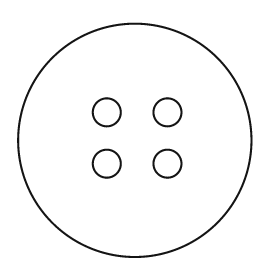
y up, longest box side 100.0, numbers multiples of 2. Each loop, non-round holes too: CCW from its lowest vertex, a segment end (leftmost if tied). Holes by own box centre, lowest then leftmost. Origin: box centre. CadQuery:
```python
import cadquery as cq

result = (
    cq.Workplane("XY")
    .moveTo(0.0, 0.0)
    .circle(50.0)
    .moveTo(-12.0, -10.0)
    .circle(6.0)
    .moveTo(14.0, -10.0)
    .circle(6.0)
    .moveTo(-12.0, 12.0)
    .circle(6.0)
    .moveTo(14.0, 12.0)
    .circle(6.0)
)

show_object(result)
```